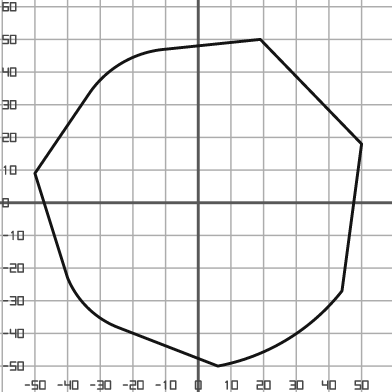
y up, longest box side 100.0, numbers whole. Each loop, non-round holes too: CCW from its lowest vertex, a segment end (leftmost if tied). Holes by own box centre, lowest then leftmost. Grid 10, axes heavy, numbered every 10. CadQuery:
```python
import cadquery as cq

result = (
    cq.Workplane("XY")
    .moveTo(6.0, -50.0)
    .threePointArc((27.0, -42.0), (44.0, -27.0))
    .lineTo(50.0, 18.0)
    .lineTo(19.0, 50.0)
    .lineTo(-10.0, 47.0)
    .threePointArc((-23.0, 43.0), (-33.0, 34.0))
    .lineTo(-50.0, 9.0)
    .lineTo(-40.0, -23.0)
    .threePointArc((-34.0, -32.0), (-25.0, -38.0))
    .close()
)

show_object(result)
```